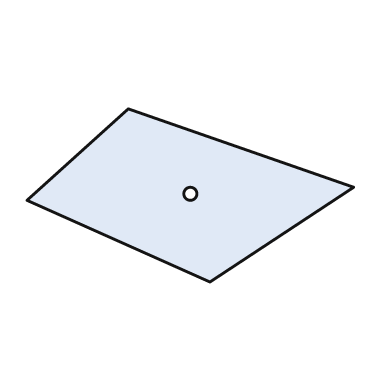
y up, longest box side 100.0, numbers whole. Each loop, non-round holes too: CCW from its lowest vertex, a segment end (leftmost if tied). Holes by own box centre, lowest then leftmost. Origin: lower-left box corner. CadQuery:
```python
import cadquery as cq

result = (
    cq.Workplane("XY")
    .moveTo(56.0, 0.0)
    .lineTo(100.0, 29.0)
    .lineTo(31.0, 53.0)
    .lineTo(0.0, 25.0)
    .close()
    .moveTo(50.0, 27.0)
    .circle(2.0)
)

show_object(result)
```